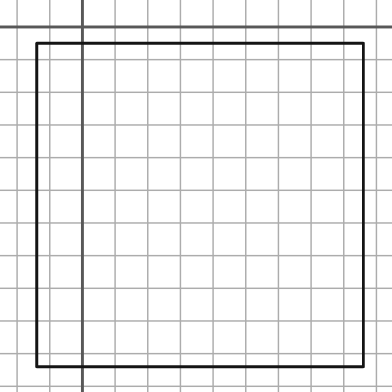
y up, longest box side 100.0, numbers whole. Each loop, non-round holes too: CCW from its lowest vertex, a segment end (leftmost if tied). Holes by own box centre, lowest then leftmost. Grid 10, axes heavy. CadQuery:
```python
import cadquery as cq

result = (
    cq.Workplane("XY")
    .moveTo(-14.0, -104.0)
    .lineTo(86.0, -104.0)
    .lineTo(86.0, -5.0)
    .lineTo(-14.0, -5.0)
    .close()
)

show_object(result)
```